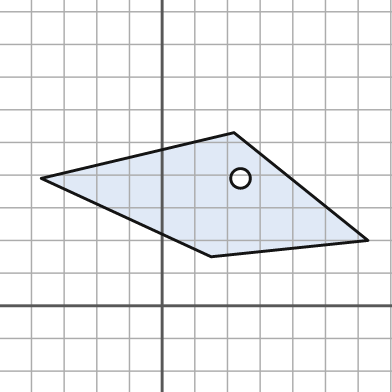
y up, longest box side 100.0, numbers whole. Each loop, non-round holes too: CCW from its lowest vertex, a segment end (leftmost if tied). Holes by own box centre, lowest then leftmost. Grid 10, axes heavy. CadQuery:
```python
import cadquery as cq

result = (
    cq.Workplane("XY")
    .moveTo(15.0, 15.0)
    .lineTo(63.0, 20.0)
    .lineTo(22.0, 53.0)
    .lineTo(-37.0, 39.0)
    .close()
    .moveTo(24.0, 39.0)
    .circle(3.0)
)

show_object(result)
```